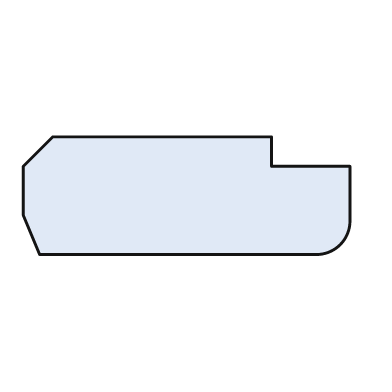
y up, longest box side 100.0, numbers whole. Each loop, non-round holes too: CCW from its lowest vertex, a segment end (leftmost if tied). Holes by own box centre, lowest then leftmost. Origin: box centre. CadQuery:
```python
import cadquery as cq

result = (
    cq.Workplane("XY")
    .moveTo(-45.0, -18.0)
    .lineTo(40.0, -18.0)
    .threePointArc((47.0, -15.0), (50.0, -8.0))
    .lineTo(50.0, 9.0)
    .lineTo(26.0, 9.0)
    .lineTo(26.0, 18.0)
    .lineTo(-41.0, 18.0)
    .lineTo(-50.0, 9.0)
    .lineTo(-50.0, -6.0)
    .close()
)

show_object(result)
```